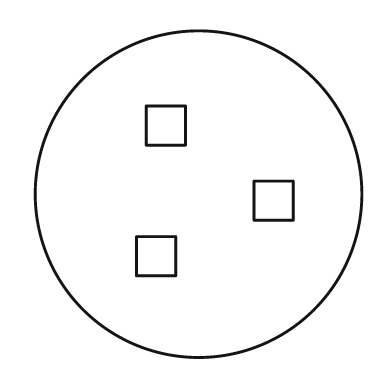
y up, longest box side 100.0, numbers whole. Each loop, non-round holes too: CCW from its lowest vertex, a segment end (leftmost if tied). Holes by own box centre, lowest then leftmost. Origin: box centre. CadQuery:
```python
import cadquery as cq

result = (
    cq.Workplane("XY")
    .moveTo(0.0, 0.0)
    .circle(50.0)
    .moveTo(-19.0, -25.0)
    .lineTo(-7.0, -25.0)
    .lineTo(-7.0, -13.0)
    .lineTo(-19.0, -13.0)
    .close()
    .moveTo(17.0, -8.0)
    .lineTo(29.0, -8.0)
    .lineTo(29.0, 4.0)
    .lineTo(17.0, 4.0)
    .close()
    .moveTo(-16.0, 15.0)
    .lineTo(-4.0, 15.0)
    .lineTo(-4.0, 27.0)
    .lineTo(-16.0, 27.0)
    .close()
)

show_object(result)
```